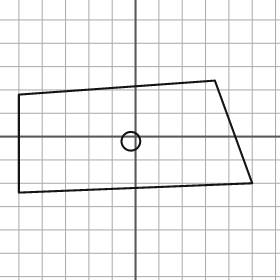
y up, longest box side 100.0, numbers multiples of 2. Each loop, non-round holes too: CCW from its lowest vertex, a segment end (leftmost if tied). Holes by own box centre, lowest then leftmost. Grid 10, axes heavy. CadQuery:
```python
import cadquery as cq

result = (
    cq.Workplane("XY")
    .moveTo(-50.0, -24.0)
    .lineTo(50.0, -20.0)
    .lineTo(34.0, 24.0)
    .lineTo(-50.0, 18.0)
    .close()
    .moveTo(-2.0, -2.0)
    .circle(4.0)
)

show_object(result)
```